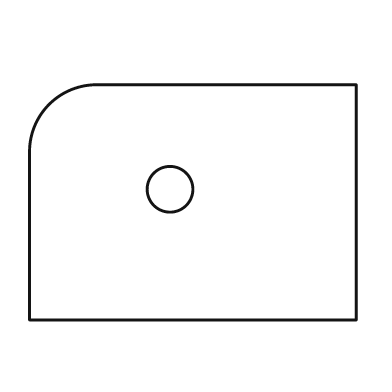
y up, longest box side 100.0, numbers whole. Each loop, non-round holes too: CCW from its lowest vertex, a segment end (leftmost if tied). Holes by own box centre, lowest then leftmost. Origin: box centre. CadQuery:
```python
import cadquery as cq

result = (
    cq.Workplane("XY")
    .moveTo(-50.0, -36.0)
    .lineTo(50.0, -36.0)
    .lineTo(50.0, 36.0)
    .lineTo(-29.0, 36.0)
    .threePointArc((-44.0, 30.0), (-50.0, 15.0))
    .close()
    .moveTo(-7.0, 4.0)
    .circle(7.0)
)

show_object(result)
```